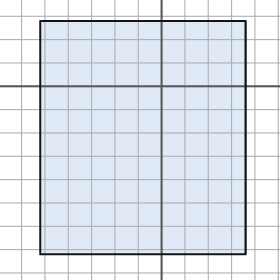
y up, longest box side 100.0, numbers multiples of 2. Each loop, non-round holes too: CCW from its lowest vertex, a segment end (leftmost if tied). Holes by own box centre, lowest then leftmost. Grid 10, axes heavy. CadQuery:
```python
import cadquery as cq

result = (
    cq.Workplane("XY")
    .moveTo(-52.0, -72.0)
    .lineTo(36.0, -72.0)
    .lineTo(36.0, 28.0)
    .lineTo(-52.0, 28.0)
    .close()
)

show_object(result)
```